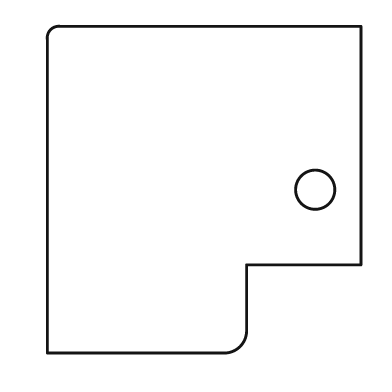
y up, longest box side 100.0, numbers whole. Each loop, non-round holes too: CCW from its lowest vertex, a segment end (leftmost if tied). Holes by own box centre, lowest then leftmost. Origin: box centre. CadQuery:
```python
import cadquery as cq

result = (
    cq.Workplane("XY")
    .moveTo(-48.0, -50.0)
    .lineTo(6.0, -50.0)
    .threePointArc((11.0, -48.0), (13.0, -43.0))
    .lineTo(13.0, -23.0)
    .lineTo(48.0, -23.0)
    .lineTo(48.0, 50.0)
    .lineTo(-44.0, 50.0)
    .threePointArc((-47.0, 49.0), (-48.0, 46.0))
    .close()
    .moveTo(34.0, 0.0)
    .circle(6.0)
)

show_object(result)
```